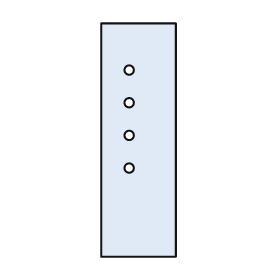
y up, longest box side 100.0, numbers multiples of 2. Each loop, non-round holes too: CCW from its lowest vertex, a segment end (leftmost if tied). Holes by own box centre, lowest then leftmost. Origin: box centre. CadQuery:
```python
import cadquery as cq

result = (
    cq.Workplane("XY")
    .moveTo(-16.0, -50.0)
    .lineTo(16.0, -50.0)
    .lineTo(16.0, 50.0)
    .lineTo(-16.0, 50.0)
    .close()
    .moveTo(-4.0, -12.0)
    .circle(2.0)
    .moveTo(-4.0, 2.0)
    .circle(2.0)
    .moveTo(-4.0, 16.0)
    .circle(2.0)
    .moveTo(-4.0, 30.0)
    .circle(2.0)
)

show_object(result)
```